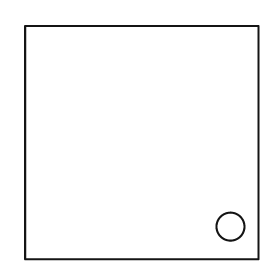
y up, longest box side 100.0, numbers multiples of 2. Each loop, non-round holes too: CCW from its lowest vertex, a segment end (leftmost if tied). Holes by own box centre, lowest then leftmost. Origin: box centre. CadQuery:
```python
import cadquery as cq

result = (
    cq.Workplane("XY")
    .moveTo(-50.0, -50.0)
    .lineTo(50.0, -50.0)
    .lineTo(50.0, 50.0)
    .lineTo(-50.0, 50.0)
    .close()
    .moveTo(38.0, -36.0)
    .circle(6.0)
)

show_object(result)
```